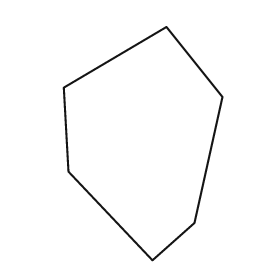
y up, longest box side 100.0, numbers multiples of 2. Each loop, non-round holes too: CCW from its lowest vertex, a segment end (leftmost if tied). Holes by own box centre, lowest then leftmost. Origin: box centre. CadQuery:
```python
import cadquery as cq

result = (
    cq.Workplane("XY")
    .moveTo(4.0, -50.0)
    .lineTo(22.0, -34.0)
    .lineTo(34.0, 20.0)
    .lineTo(10.0, 50.0)
    .lineTo(-34.0, 24.0)
    .lineTo(-32.0, -12.0)
    .close()
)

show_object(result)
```